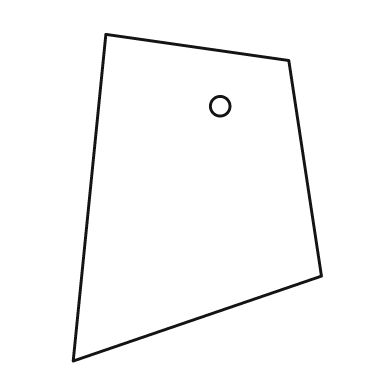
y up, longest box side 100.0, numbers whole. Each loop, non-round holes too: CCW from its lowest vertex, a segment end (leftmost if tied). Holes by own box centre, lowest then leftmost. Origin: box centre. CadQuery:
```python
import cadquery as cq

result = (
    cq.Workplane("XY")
    .moveTo(-38.0, -50.0)
    .lineTo(38.0, -24.0)
    .lineTo(28.0, 42.0)
    .lineTo(-28.0, 50.0)
    .close()
    .moveTo(7.0, 28.0)
    .circle(3.0)
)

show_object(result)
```